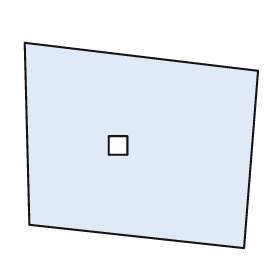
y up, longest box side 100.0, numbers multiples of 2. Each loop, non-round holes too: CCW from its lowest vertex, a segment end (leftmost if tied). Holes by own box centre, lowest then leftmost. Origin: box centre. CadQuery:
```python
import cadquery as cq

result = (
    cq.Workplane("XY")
    .moveTo(44.0, -44.0)
    .lineTo(50.0, 32.0)
    .lineTo(-50.0, 44.0)
    .lineTo(-48.0, -34.0)
    .close()
    .moveTo(-14.0, -4.0)
    .lineTo(-6.0, -4.0)
    .lineTo(-6.0, 4.0)
    .lineTo(-14.0, 4.0)
    .close()
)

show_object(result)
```